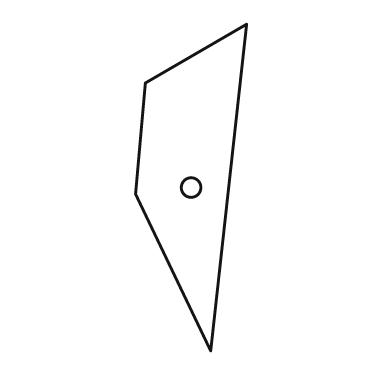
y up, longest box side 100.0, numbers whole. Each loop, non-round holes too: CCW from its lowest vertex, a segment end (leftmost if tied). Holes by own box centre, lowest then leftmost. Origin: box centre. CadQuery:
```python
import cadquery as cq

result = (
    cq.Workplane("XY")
    .moveTo(6.0, -50.0)
    .lineTo(17.0, 50.0)
    .lineTo(-14.0, 32.0)
    .lineTo(-17.0, -2.0)
    .close()
    .moveTo(0.0, 0.0)
    .circle(3.0)
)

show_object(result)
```